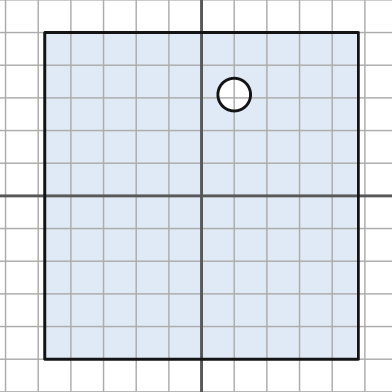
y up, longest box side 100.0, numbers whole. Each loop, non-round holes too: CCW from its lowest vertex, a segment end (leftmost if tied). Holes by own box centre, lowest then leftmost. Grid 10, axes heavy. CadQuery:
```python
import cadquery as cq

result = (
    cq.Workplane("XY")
    .moveTo(-48.0, -50.0)
    .lineTo(48.0, -50.0)
    .lineTo(48.0, 50.0)
    .lineTo(-48.0, 50.0)
    .close()
    .moveTo(10.0, 31.0)
    .circle(5.0)
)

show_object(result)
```